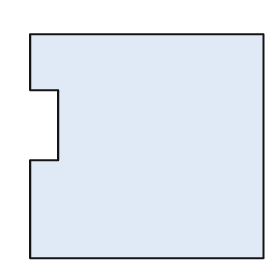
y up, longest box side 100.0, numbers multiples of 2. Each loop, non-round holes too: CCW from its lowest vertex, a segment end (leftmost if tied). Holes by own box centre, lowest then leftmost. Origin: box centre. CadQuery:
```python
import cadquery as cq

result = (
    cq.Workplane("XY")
    .moveTo(-50.0, -48.0)
    .lineTo(50.0, -48.0)
    .lineTo(50.0, 48.0)
    .lineTo(-50.0, 48.0)
    .lineTo(-50.0, 24.0)
    .lineTo(-38.0, 24.0)
    .lineTo(-38.0, -6.0)
    .lineTo(-50.0, -6.0)
    .close()
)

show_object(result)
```